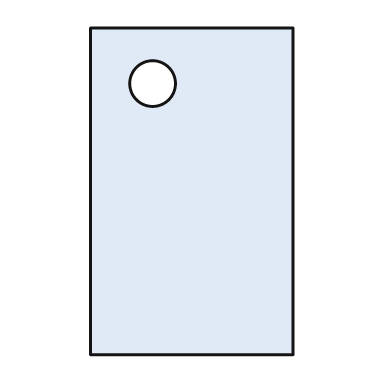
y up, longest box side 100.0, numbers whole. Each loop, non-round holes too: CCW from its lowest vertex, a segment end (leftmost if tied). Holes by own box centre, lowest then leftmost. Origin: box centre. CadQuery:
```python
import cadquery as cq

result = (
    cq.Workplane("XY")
    .moveTo(-31.0, -50.0)
    .lineTo(31.0, -50.0)
    .lineTo(31.0, 50.0)
    .lineTo(-31.0, 50.0)
    .close()
    .moveTo(-12.0, 33.0)
    .circle(7.0)
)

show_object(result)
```